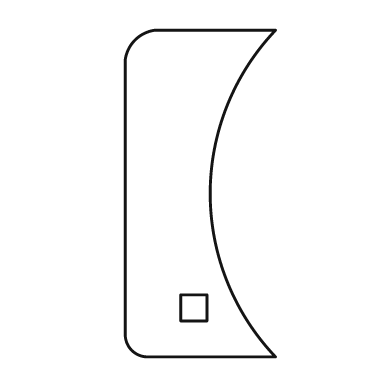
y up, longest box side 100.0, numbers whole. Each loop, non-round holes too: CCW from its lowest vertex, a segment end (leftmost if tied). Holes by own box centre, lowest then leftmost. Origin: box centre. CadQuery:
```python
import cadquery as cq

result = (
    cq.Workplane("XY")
    .moveTo(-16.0, -50.0)
    .lineTo(23.0, -50.0)
    .threePointArc((3.0, 0.0), (23.0, 50.0))
    .lineTo(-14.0, 50.0)
    .threePointArc((-20.0, 47.0), (-23.0, 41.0))
    .lineTo(-23.0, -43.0)
    .threePointArc((-21.0, -48.0), (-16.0, -50.0))
    .close()
    .moveTo(-6.0, -39.0)
    .lineTo(2.0, -39.0)
    .lineTo(2.0, -31.0)
    .lineTo(-6.0, -31.0)
    .close()
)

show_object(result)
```